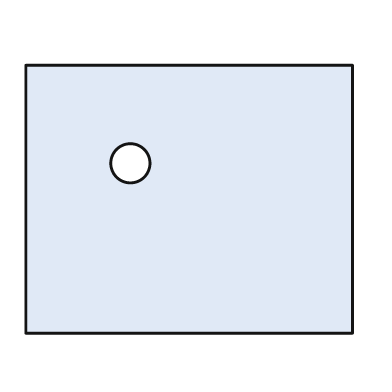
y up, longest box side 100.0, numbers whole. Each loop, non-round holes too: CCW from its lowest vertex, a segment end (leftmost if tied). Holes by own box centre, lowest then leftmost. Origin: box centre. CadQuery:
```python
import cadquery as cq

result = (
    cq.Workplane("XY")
    .moveTo(-50.0, -41.0)
    .lineTo(50.0, -41.0)
    .lineTo(50.0, 41.0)
    .lineTo(-50.0, 41.0)
    .close()
    .moveTo(-18.0, 11.0)
    .circle(6.0)
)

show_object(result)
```